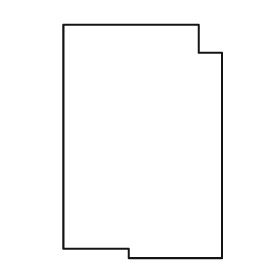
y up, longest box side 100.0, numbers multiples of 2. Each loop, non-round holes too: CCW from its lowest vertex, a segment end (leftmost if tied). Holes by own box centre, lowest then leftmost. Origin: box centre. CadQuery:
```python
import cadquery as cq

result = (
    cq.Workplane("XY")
    .moveTo(-6.0, -50.0)
    .lineTo(34.0, -50.0)
    .lineTo(34.0, 38.0)
    .lineTo(24.0, 38.0)
    .lineTo(24.0, 50.0)
    .lineTo(-34.0, 50.0)
    .lineTo(-34.0, -46.0)
    .lineTo(-6.0, -46.0)
    .close()
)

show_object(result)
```